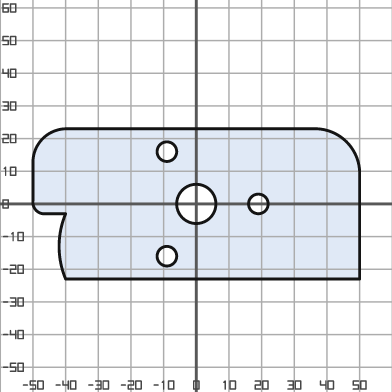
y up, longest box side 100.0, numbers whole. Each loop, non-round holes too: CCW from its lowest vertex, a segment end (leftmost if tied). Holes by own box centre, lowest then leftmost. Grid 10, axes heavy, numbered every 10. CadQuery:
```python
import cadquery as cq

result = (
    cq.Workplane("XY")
    .moveTo(-40.0, -23.0)
    .lineTo(50.0, -23.0)
    .lineTo(50.0, 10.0)
    .threePointArc((46.0, 19.0), (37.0, 23.0))
    .lineTo(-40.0, 23.0)
    .threePointArc((-47.0, 20.0), (-50.0, 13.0))
    .lineTo(-50.0, 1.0)
    .threePointArc((-49.0, -2.0), (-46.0, -3.0))
    .lineTo(-40.0, -3.0)
    .threePointArc((-42.0, -13.0), (-40.0, -23.0))
    .close()
    .moveTo(-9.0, -16.0)
    .circle(3.0)
    .moveTo(0.0, 0.0)
    .circle(6.0)
    .moveTo(19.0, 0.0)
    .circle(3.0)
    .moveTo(-9.0, 16.0)
    .circle(3.0)
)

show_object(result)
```